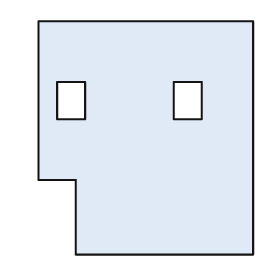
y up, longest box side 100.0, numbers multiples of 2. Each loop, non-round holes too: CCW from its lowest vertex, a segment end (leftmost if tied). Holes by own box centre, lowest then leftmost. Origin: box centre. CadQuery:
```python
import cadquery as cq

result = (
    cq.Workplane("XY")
    .moveTo(-30.0, -50.0)
    .lineTo(46.0, -50.0)
    .lineTo(46.0, 50.0)
    .lineTo(-46.0, 50.0)
    .lineTo(-46.0, -18.0)
    .lineTo(-30.0, -18.0)
    .close()
    .moveTo(-38.0, 8.0)
    .lineTo(-26.0, 8.0)
    .lineTo(-26.0, 24.0)
    .lineTo(-38.0, 24.0)
    .close()
    .moveTo(12.0, 8.0)
    .lineTo(24.0, 8.0)
    .lineTo(24.0, 24.0)
    .lineTo(12.0, 24.0)
    .close()
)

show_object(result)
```